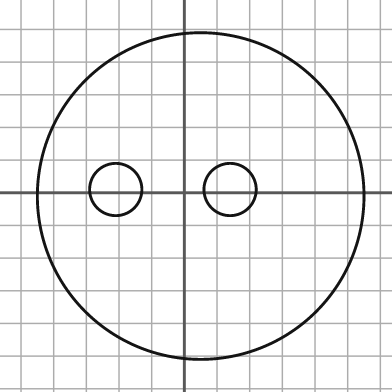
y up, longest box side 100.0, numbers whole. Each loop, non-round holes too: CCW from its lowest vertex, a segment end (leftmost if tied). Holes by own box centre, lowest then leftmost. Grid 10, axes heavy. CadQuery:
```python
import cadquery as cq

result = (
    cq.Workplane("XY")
    .moveTo(5.0, -1.0)
    .circle(50.0)
    .moveTo(-21.0, 1.0)
    .circle(8.0)
    .moveTo(14.0, 1.0)
    .circle(8.0)
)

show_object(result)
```